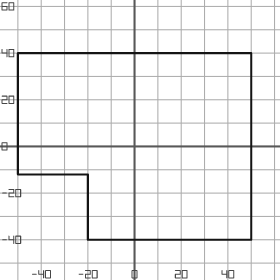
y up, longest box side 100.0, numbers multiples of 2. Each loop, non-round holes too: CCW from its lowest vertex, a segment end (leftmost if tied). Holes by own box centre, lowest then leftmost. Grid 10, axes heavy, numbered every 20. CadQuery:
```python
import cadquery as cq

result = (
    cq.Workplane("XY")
    .moveTo(-20.0, -40.0)
    .lineTo(50.0, -40.0)
    .lineTo(50.0, 40.0)
    .lineTo(-50.0, 40.0)
    .lineTo(-50.0, -12.0)
    .lineTo(-20.0, -12.0)
    .close()
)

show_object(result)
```